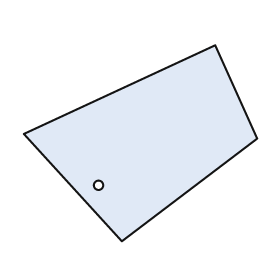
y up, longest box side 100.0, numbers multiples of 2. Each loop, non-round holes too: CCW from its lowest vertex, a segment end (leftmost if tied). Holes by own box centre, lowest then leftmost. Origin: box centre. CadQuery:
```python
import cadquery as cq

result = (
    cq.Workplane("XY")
    .moveTo(-8.0, -42.0)
    .lineTo(50.0, 2.0)
    .lineTo(32.0, 42.0)
    .lineTo(-50.0, 4.0)
    .close()
    .moveTo(-18.0, -18.0)
    .circle(2.0)
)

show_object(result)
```